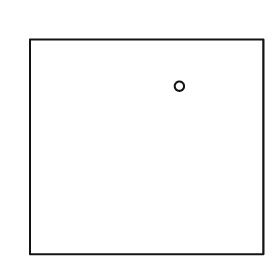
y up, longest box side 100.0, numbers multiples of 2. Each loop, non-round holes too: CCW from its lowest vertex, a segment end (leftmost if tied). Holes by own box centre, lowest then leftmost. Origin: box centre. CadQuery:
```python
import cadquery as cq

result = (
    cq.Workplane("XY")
    .moveTo(-50.0, -46.0)
    .lineTo(50.0, -46.0)
    .lineTo(50.0, 46.0)
    .lineTo(-50.0, 46.0)
    .close()
    .moveTo(14.0, 26.0)
    .circle(2.0)
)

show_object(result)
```